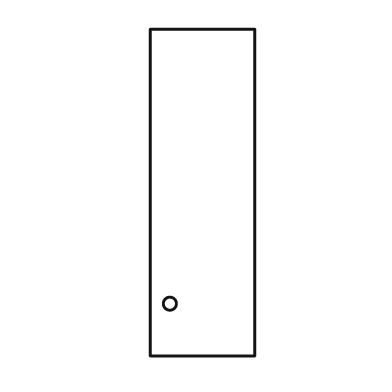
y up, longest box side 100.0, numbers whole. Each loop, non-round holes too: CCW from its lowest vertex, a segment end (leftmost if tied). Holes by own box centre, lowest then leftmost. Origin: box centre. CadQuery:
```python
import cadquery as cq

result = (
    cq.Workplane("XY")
    .moveTo(-16.0, -50.0)
    .lineTo(16.0, -50.0)
    .lineTo(16.0, 50.0)
    .lineTo(-16.0, 50.0)
    .close()
    .moveTo(-10.0, -34.0)
    .circle(2.0)
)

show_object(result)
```